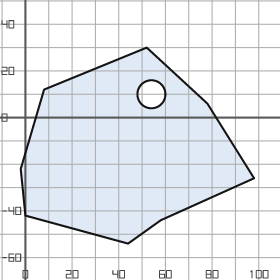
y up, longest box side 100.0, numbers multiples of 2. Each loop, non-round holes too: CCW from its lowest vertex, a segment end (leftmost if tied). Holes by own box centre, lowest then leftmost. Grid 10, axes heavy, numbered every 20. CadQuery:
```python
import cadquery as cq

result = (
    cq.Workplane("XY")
    .moveTo(44.0, -54.0)
    .lineTo(58.0, -44.0)
    .lineTo(98.0, -26.0)
    .lineTo(78.0, 6.0)
    .lineTo(52.0, 30.0)
    .lineTo(8.0, 12.0)
    .lineTo(-2.0, -22.0)
    .lineTo(0.0, -42.0)
    .close()
    .moveTo(54.0, 10.0)
    .circle(6.0)
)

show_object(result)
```